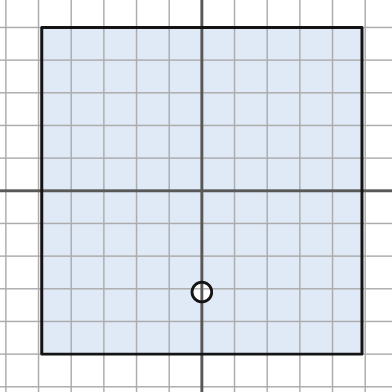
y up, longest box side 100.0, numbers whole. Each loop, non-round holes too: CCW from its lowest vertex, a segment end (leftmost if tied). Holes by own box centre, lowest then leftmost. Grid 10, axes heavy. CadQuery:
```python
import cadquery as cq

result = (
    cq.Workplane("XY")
    .moveTo(-49.0, -50.0)
    .lineTo(49.0, -50.0)
    .lineTo(49.0, 50.0)
    .lineTo(-49.0, 50.0)
    .close()
    .moveTo(0.0, -31.0)
    .circle(3.0)
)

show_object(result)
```